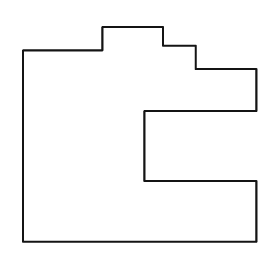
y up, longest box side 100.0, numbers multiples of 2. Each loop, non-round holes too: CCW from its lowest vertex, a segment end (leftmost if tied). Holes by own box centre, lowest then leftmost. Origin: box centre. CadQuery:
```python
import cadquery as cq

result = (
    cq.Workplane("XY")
    .moveTo(-50.0, -46.0)
    .lineTo(50.0, -46.0)
    .lineTo(50.0, -20.0)
    .lineTo(2.0, -20.0)
    .lineTo(2.0, 10.0)
    .lineTo(50.0, 10.0)
    .lineTo(50.0, 28.0)
    .lineTo(24.0, 28.0)
    .lineTo(24.0, 38.0)
    .lineTo(10.0, 38.0)
    .lineTo(10.0, 46.0)
    .lineTo(-16.0, 46.0)
    .lineTo(-16.0, 36.0)
    .lineTo(-50.0, 36.0)
    .close()
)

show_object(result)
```